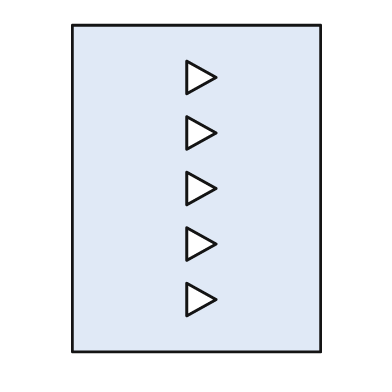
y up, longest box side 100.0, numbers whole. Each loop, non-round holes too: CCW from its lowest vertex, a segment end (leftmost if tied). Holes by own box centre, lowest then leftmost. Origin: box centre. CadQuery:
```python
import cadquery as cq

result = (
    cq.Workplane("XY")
    .moveTo(-38.0, -50.0)
    .lineTo(38.0, -50.0)
    .lineTo(38.0, 50.0)
    .lineTo(-38.0, 50.0)
    .close()
    .moveTo(-3.0, -39.0)
    .lineTo(6.0, -34.0)
    .lineTo(-3.0, -29.0)
    .close()
    .moveTo(-3.0, -22.0)
    .lineTo(6.0, -17.0)
    .lineTo(-3.0, -12.0)
    .close()
    .moveTo(-3.0, -5.0)
    .lineTo(6.0, 0.0)
    .lineTo(-3.0, 5.0)
    .close()
    .moveTo(-3.0, 12.0)
    .lineTo(6.0, 17.0)
    .lineTo(-3.0, 22.0)
    .close()
    .moveTo(-3.0, 29.0)
    .lineTo(6.0, 34.0)
    .lineTo(-3.0, 39.0)
    .close()
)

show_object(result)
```